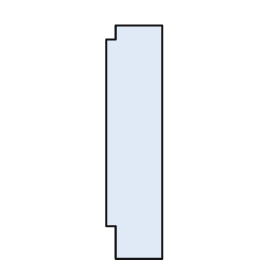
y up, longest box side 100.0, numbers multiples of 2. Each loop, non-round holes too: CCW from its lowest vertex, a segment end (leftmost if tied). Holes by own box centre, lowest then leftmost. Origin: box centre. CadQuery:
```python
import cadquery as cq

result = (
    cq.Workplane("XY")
    .moveTo(-8.0, -50.0)
    .lineTo(12.0, -50.0)
    .lineTo(12.0, 50.0)
    .lineTo(-8.0, 50.0)
    .lineTo(-8.0, 44.0)
    .lineTo(-12.0, 44.0)
    .lineTo(-12.0, -36.0)
    .lineTo(-8.0, -36.0)
    .close()
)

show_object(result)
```